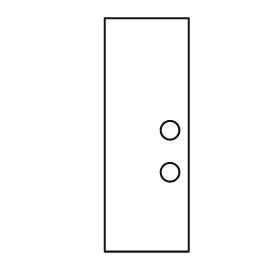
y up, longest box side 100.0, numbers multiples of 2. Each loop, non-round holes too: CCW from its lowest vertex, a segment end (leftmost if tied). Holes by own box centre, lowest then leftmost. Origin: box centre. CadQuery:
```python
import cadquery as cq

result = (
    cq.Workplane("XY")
    .moveTo(-18.0, -50.0)
    .lineTo(18.0, -50.0)
    .lineTo(18.0, 50.0)
    .lineTo(-18.0, 50.0)
    .close()
    .moveTo(10.0, -16.0)
    .circle(4.0)
    .moveTo(10.0, 2.0)
    .circle(4.0)
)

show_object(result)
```